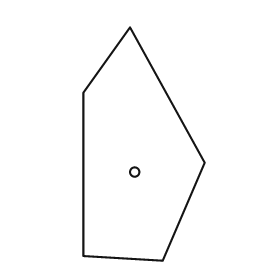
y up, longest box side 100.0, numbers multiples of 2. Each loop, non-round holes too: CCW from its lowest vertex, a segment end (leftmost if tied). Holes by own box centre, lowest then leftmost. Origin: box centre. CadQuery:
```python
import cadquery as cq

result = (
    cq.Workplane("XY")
    .moveTo(8.0, -50.0)
    .lineTo(26.0, -8.0)
    .lineTo(-6.0, 50.0)
    .lineTo(-26.0, 22.0)
    .lineTo(-26.0, -48.0)
    .close()
    .moveTo(-4.0, -12.0)
    .circle(2.0)
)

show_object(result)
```